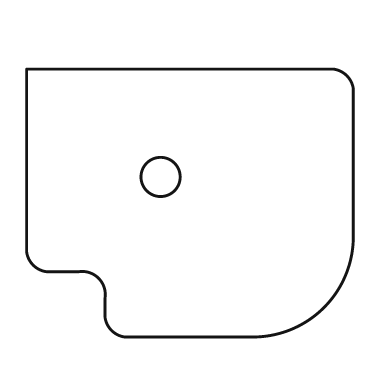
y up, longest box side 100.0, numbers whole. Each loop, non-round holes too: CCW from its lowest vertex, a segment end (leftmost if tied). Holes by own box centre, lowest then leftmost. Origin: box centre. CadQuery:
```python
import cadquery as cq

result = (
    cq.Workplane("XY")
    .moveTo(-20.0, -41.0)
    .lineTo(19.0, -41.0)
    .threePointArc((41.0, -32.0), (50.0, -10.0))
    .lineTo(50.0, 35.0)
    .threePointArc((48.0, 39.0), (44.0, 41.0))
    .lineTo(-50.0, 41.0)
    .lineTo(-50.0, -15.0)
    .threePointArc((-48.0, -19.0), (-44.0, -21.0))
    .lineTo(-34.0, -21.0)
    .threePointArc((-28.0, -23.0), (-26.0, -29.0))
    .lineTo(-26.0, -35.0)
    .threePointArc((-24.0, -39.0), (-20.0, -41.0))
    .close()
    .moveTo(-9.0, 8.0)
    .circle(6.0)
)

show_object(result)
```